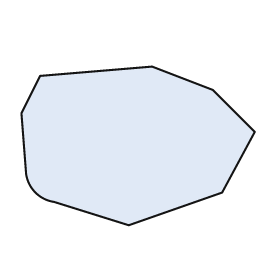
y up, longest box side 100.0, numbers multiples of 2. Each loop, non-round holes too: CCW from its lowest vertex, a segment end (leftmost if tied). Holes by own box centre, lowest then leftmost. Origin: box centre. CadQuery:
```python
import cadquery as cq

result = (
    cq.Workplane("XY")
    .moveTo(-4.0, -34.0)
    .lineTo(36.0, -20.0)
    .lineTo(50.0, 6.0)
    .lineTo(32.0, 24.0)
    .lineTo(6.0, 34.0)
    .lineTo(-42.0, 30.0)
    .lineTo(-50.0, 14.0)
    .lineTo(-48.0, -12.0)
    .threePointArc((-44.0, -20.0), (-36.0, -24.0))
    .close()
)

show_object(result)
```